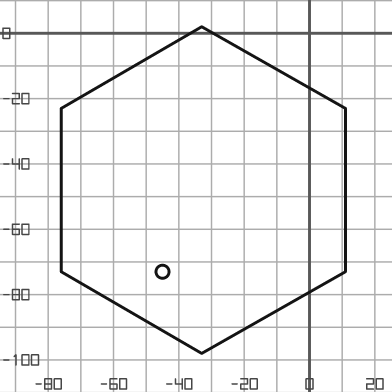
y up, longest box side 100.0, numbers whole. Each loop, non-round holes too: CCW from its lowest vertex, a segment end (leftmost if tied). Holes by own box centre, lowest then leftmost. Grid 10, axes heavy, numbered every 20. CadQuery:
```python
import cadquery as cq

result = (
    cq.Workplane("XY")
    .moveTo(-33.0, -98.0)
    .lineTo(11.0, -73.0)
    .lineTo(11.0, -23.0)
    .lineTo(-33.0, 2.0)
    .lineTo(-76.0, -23.0)
    .lineTo(-76.0, -73.0)
    .close()
    .moveTo(-45.0, -73.0)
    .circle(2.0)
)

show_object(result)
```